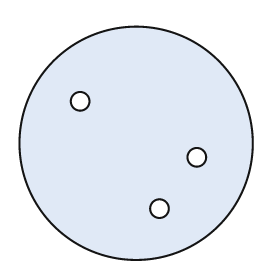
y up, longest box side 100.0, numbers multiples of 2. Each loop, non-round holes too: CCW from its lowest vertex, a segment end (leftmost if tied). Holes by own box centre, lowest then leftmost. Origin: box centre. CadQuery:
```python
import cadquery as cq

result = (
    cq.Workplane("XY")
    .moveTo(0.0, 0.0)
    .circle(50.0)
    .moveTo(10.0, -28.0)
    .circle(4.0)
    .moveTo(26.0, -6.0)
    .circle(4.0)
    .moveTo(-24.0, 18.0)
    .circle(4.0)
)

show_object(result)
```